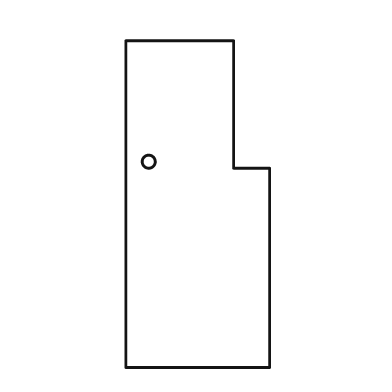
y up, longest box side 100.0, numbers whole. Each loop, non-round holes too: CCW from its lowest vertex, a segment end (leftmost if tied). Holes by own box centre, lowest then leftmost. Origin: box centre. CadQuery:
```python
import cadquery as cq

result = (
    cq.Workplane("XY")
    .moveTo(-22.0, -50.0)
    .lineTo(22.0, -50.0)
    .lineTo(22.0, 11.0)
    .lineTo(11.0, 11.0)
    .lineTo(11.0, 50.0)
    .lineTo(-22.0, 50.0)
    .close()
    .moveTo(-15.0, 13.0)
    .circle(2.0)
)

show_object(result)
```